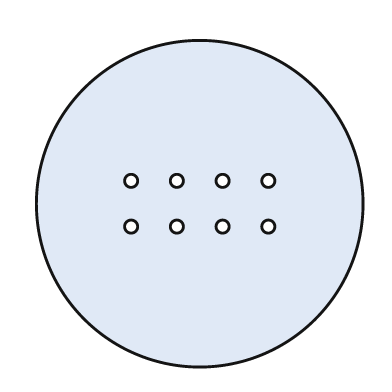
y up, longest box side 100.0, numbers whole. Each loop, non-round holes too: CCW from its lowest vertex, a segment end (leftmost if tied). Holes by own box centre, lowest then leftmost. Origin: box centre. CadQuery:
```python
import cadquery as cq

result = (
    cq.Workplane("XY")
    .moveTo(0.0, 0.0)
    .circle(50.0)
    .moveTo(-21.0, -7.0)
    .circle(2.0)
    .moveTo(-7.0, -7.0)
    .circle(2.0)
    .moveTo(7.0, -7.0)
    .circle(2.0)
    .moveTo(21.0, -7.0)
    .circle(2.0)
    .moveTo(-21.0, 7.0)
    .circle(2.0)
    .moveTo(-7.0, 7.0)
    .circle(2.0)
    .moveTo(7.0, 7.0)
    .circle(2.0)
    .moveTo(21.0, 7.0)
    .circle(2.0)
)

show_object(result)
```